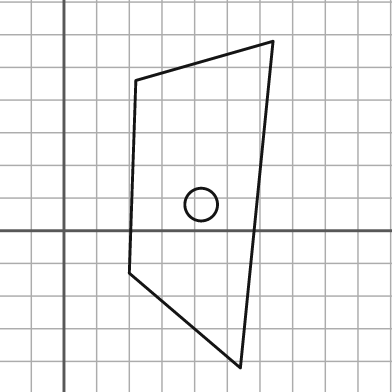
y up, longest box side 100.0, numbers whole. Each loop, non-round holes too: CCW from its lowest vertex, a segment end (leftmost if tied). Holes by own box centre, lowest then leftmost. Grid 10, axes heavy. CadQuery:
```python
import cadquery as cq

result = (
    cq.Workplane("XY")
    .moveTo(54.0, -42.0)
    .lineTo(64.0, 58.0)
    .lineTo(22.0, 46.0)
    .lineTo(20.0, -13.0)
    .close()
    .moveTo(42.0, 8.0)
    .circle(5.0)
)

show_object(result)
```